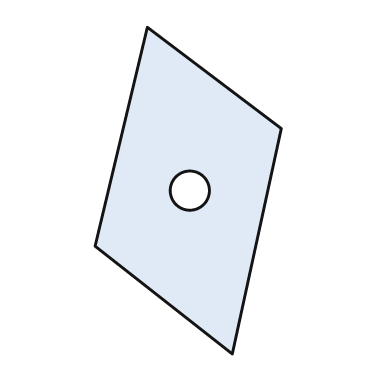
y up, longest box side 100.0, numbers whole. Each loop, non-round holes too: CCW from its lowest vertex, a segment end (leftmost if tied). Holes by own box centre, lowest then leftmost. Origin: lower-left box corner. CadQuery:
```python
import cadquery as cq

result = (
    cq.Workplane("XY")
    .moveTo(42.0, 0.0)
    .lineTo(57.0, 69.0)
    .lineTo(16.0, 100.0)
    .lineTo(0.0, 33.0)
    .close()
    .moveTo(29.0, 50.0)
    .circle(6.0)
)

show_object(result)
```